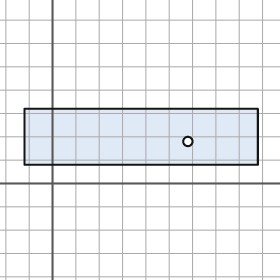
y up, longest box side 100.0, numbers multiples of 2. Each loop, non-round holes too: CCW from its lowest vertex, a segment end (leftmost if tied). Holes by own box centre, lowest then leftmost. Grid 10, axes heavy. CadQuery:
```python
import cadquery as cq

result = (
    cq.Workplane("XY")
    .moveTo(-12.0, 8.0)
    .lineTo(88.0, 8.0)
    .lineTo(88.0, 32.0)
    .lineTo(-12.0, 32.0)
    .close()
    .moveTo(58.0, 18.0)
    .circle(2.0)
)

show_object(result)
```